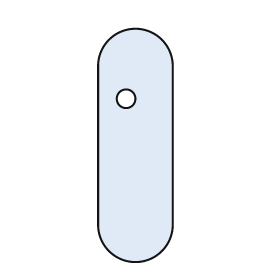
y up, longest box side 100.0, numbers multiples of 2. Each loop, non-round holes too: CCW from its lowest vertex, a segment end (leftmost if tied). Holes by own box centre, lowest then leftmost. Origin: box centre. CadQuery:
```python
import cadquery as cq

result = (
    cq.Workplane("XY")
    .moveTo(-16.0, -34.0)
    .threePointArc((0.0, -50.0), (16.0, -34.0))
    .lineTo(16.0, 34.0)
    .threePointArc((0.0, 50.0), (-16.0, 34.0))
    .close()
    .moveTo(-4.0, 20.0)
    .circle(4.0)
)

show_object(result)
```